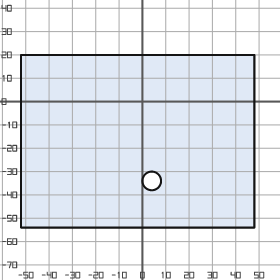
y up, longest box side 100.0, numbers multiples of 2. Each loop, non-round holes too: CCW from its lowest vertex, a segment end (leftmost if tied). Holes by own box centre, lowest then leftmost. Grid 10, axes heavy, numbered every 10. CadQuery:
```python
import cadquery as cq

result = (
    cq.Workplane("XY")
    .moveTo(-52.0, -54.0)
    .lineTo(48.0, -54.0)
    .lineTo(48.0, 20.0)
    .lineTo(-52.0, 20.0)
    .close()
    .moveTo(4.0, -34.0)
    .circle(4.0)
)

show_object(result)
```